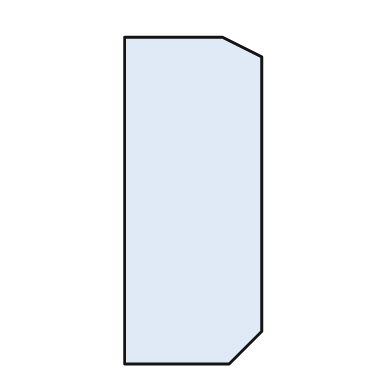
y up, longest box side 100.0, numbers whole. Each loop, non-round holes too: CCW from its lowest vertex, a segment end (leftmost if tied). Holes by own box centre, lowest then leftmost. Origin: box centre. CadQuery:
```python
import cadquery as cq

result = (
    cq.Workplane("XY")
    .moveTo(-21.0, -50.0)
    .lineTo(11.0, -50.0)
    .lineTo(21.0, -40.0)
    .lineTo(21.0, 44.0)
    .lineTo(9.0, 50.0)
    .lineTo(-21.0, 50.0)
    .close()
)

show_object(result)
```